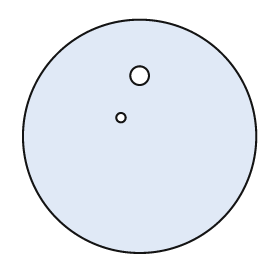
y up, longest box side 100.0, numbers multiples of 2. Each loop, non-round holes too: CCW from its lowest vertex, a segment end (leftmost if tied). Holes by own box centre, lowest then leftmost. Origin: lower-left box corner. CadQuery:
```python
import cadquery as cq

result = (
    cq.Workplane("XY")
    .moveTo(50.0, 50.0)
    .circle(50.0)
    .moveTo(42.0, 58.0)
    .circle(2.0)
    .moveTo(50.0, 76.0)
    .circle(4.0)
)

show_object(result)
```